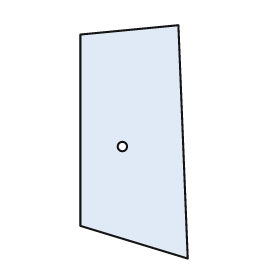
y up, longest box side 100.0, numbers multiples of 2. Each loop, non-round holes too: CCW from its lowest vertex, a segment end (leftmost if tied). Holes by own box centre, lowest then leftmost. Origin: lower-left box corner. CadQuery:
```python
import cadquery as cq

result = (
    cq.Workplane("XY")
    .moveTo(46.0, 0.0)
    .lineTo(42.0, 100.0)
    .lineTo(0.0, 96.0)
    .lineTo(0.0, 14.0)
    .close()
    .moveTo(18.0, 48.0)
    .circle(2.0)
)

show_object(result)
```